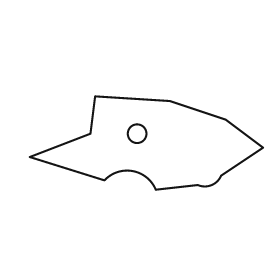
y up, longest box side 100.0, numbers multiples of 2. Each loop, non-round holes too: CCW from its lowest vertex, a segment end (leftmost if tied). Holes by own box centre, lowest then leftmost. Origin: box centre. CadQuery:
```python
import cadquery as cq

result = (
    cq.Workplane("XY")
    .moveTo(4.0, -20.0)
    .lineTo(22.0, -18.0)
    .threePointArc((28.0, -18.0), (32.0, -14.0))
    .lineTo(50.0, -2.0)
    .lineTo(34.0, 10.0)
    .lineTo(10.0, 18.0)
    .lineTo(-22.0, 20.0)
    .lineTo(-24.0, 4.0)
    .lineTo(-50.0, -6.0)
    .lineTo(-18.0, -16.0)
    .threePointArc((-6.0, -12.0), (4.0, -20.0))
    .close()
    .moveTo(-4.0, 4.0)
    .circle(4.0)
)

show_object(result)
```